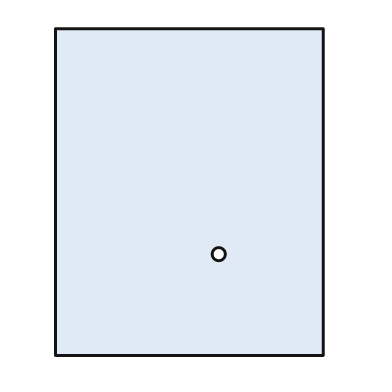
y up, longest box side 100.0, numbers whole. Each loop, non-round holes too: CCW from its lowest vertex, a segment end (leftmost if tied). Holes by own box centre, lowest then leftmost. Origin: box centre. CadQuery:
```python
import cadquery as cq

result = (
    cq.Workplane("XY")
    .moveTo(-41.0, -50.0)
    .lineTo(41.0, -50.0)
    .lineTo(41.0, 50.0)
    .lineTo(-41.0, 50.0)
    .close()
    .moveTo(9.0, -19.0)
    .circle(2.0)
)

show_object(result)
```